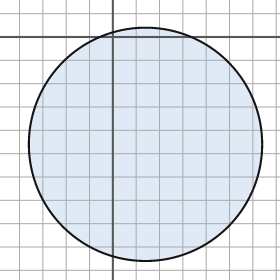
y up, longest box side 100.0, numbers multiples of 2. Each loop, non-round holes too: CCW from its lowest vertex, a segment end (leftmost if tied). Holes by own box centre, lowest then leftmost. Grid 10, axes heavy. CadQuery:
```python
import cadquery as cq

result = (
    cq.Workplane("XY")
    .moveTo(14.0, -46.0)
    .circle(50.0)
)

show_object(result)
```